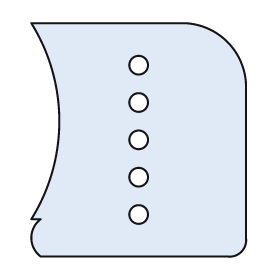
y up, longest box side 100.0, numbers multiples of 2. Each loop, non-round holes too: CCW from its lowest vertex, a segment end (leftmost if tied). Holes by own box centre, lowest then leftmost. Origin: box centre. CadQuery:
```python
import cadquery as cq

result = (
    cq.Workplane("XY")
    .moveTo(-42.0, -50.0)
    .lineTo(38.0, -50.0)
    .threePointArc((44.0, -48.0), (46.0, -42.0))
    .lineTo(46.0, 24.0)
    .threePointArc((38.0, 42.0), (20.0, 50.0))
    .lineTo(-46.0, 50.0)
    .threePointArc((-34.0, 8.0), (-46.0, -34.0))
    .lineTo(-42.0, -34.0)
    .threePointArc((-46.0, -42.0), (-42.0, -50.0))
    .close()
    .moveTo(0.0, -32.0)
    .circle(4.0)
    .moveTo(0.0, -16.0)
    .circle(4.0)
    .moveTo(0.0, 0.0)
    .circle(4.0)
    .moveTo(0.0, 16.0)
    .circle(4.0)
    .moveTo(0.0, 32.0)
    .circle(4.0)
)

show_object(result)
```